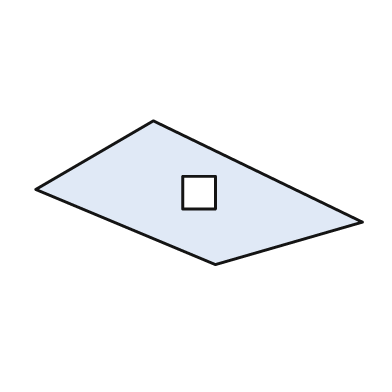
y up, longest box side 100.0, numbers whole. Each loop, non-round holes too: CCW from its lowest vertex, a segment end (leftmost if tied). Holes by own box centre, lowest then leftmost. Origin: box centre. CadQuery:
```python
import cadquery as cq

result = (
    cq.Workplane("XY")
    .moveTo(5.0, -22.0)
    .lineTo(50.0, -9.0)
    .lineTo(-14.0, 22.0)
    .lineTo(-50.0, 1.0)
    .close()
    .moveTo(-5.0, -5.0)
    .lineTo(5.0, -5.0)
    .lineTo(5.0, 5.0)
    .lineTo(-5.0, 5.0)
    .close()
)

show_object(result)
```